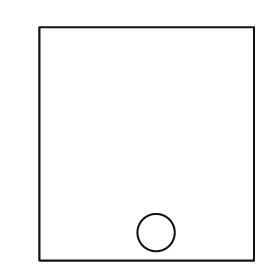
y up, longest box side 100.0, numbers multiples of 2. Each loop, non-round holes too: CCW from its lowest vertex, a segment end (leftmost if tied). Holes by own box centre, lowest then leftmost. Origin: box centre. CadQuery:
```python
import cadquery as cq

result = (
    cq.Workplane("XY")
    .moveTo(-46.0, -50.0)
    .lineTo(46.0, -50.0)
    .lineTo(46.0, 50.0)
    .lineTo(-46.0, 50.0)
    .close()
    .moveTo(4.0, -38.0)
    .circle(8.0)
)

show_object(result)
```